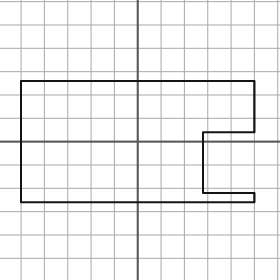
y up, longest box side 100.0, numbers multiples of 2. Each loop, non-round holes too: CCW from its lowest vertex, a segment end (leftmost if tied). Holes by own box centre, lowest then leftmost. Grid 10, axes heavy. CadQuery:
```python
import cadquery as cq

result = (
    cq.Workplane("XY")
    .moveTo(-50.0, -26.0)
    .lineTo(50.0, -26.0)
    .lineTo(50.0, -22.0)
    .lineTo(28.0, -22.0)
    .lineTo(28.0, 4.0)
    .lineTo(50.0, 4.0)
    .lineTo(50.0, 26.0)
    .lineTo(-50.0, 26.0)
    .close()
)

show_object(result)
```